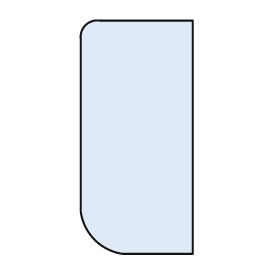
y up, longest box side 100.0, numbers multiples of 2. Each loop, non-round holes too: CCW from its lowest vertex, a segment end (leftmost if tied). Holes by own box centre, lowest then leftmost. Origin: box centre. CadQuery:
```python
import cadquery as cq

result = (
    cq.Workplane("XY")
    .moveTo(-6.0, -50.0)
    .lineTo(24.0, -50.0)
    .lineTo(24.0, 50.0)
    .lineTo(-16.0, 50.0)
    .threePointArc((-22.0, 48.0), (-24.0, 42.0))
    .lineTo(-24.0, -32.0)
    .threePointArc((-18.0, -44.0), (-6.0, -50.0))
    .close()
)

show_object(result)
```